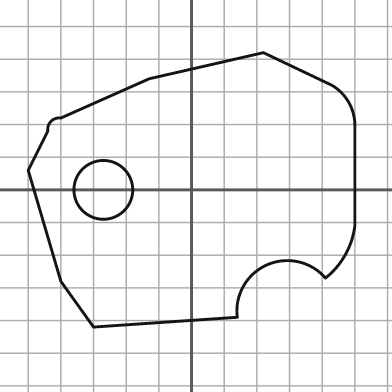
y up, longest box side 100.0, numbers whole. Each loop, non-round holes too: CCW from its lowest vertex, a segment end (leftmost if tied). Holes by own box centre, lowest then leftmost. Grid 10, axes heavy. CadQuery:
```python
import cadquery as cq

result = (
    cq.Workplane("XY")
    .moveTo(-30.0, -42.0)
    .lineTo(14.0, -39.0)
    .threePointArc((23.0, -23.0), (41.0, -27.0))
    .threePointArc((47.0, -20.0), (50.0, -11.0))
    .lineTo(50.0, 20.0)
    .threePointArc((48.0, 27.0), (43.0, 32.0))
    .lineTo(22.0, 42.0)
    .lineTo(-13.0, 34.0)
    .lineTo(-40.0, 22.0)
    .threePointArc((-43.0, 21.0), (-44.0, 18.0))
    .lineTo(-50.0, 6.0)
    .lineTo(-40.0, -28.0)
    .close()
    .moveTo(-27.0, 0.0)
    .circle(9.0)
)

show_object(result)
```